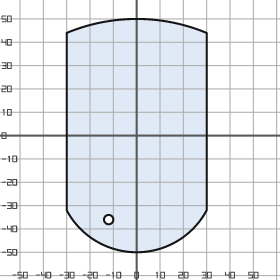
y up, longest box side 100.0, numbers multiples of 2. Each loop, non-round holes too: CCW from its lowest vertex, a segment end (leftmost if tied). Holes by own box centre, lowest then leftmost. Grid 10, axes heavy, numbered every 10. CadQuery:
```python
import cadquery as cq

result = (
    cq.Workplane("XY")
    .moveTo(-30.0, -32.0)
    .threePointArc((0.0, -50.0), (30.0, -32.0))
    .lineTo(30.0, 44.0)
    .threePointArc((0.0, 50.0), (-30.0, 44.0))
    .close()
    .moveTo(-12.0, -36.0)
    .circle(2.0)
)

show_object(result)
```